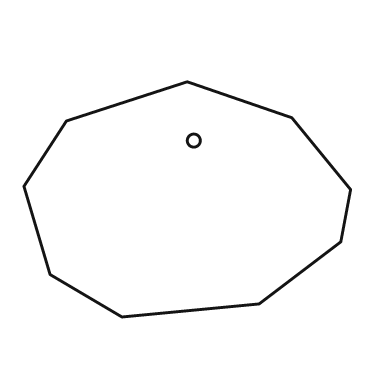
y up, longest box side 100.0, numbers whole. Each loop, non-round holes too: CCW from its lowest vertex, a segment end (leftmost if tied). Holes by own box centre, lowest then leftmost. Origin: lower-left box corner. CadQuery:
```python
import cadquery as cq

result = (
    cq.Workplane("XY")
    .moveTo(30.0, 0.0)
    .lineTo(72.0, 4.0)
    .lineTo(97.0, 23.0)
    .lineTo(100.0, 39.0)
    .lineTo(82.0, 61.0)
    .lineTo(50.0, 72.0)
    .lineTo(13.0, 60.0)
    .lineTo(0.0, 40.0)
    .lineTo(8.0, 13.0)
    .close()
    .moveTo(52.0, 54.0)
    .circle(2.0)
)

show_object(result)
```